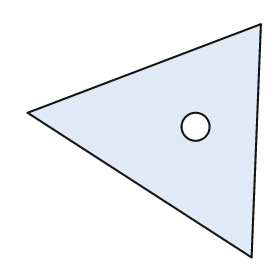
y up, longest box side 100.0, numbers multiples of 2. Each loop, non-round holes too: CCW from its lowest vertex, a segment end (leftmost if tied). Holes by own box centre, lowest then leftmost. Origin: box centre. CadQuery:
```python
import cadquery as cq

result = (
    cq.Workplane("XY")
    .moveTo(46.0, -50.0)
    .lineTo(50.0, 50.0)
    .lineTo(-50.0, 12.0)
    .close()
    .moveTo(22.0, 6.0)
    .circle(6.0)
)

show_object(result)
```